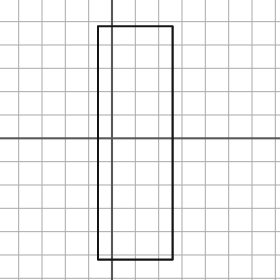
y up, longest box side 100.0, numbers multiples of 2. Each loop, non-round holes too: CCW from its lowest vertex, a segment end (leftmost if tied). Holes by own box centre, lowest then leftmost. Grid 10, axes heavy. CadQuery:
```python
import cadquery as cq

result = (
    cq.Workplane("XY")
    .moveTo(-6.0, -52.0)
    .lineTo(26.0, -52.0)
    .lineTo(26.0, 48.0)
    .lineTo(-6.0, 48.0)
    .close()
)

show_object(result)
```